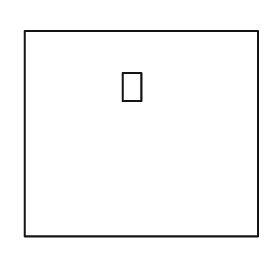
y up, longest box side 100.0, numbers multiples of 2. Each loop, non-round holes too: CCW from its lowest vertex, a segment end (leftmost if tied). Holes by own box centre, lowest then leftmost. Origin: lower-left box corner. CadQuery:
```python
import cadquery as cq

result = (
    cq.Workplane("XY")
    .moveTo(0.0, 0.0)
    .lineTo(100.0, 0.0)
    .lineTo(100.0, 88.0)
    .lineTo(0.0, 88.0)
    .close()
    .moveTo(42.0, 58.0)
    .lineTo(50.0, 58.0)
    .lineTo(50.0, 70.0)
    .lineTo(42.0, 70.0)
    .close()
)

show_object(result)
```